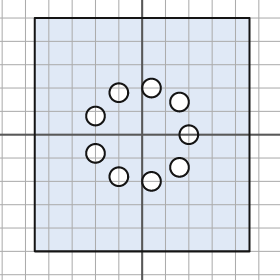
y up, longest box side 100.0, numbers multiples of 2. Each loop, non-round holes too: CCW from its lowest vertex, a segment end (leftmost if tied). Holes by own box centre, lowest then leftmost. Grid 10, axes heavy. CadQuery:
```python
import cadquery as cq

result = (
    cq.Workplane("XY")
    .moveTo(-46.0, -50.0)
    .lineTo(46.0, -50.0)
    .lineTo(46.0, 50.0)
    .lineTo(-46.0, 50.0)
    .close()
    .moveTo(4.0, -20.0)
    .circle(4.0)
    .moveTo(-10.0, -18.0)
    .circle(4.0)
    .moveTo(16.0, -14.0)
    .circle(4.0)
    .moveTo(-20.0, -8.0)
    .circle(4.0)
    .moveTo(20.0, 0.0)
    .circle(4.0)
    .moveTo(-20.0, 8.0)
    .circle(4.0)
    .moveTo(16.0, 14.0)
    .circle(4.0)
    .moveTo(-10.0, 18.0)
    .circle(4.0)
    .moveTo(4.0, 20.0)
    .circle(4.0)
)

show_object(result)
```